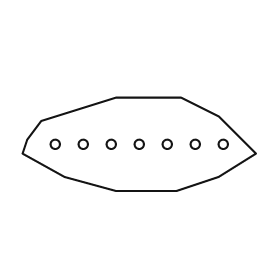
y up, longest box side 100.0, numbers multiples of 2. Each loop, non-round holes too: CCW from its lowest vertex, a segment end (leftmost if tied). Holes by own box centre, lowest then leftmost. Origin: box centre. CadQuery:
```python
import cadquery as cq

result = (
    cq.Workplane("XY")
    .moveTo(-10.0, -20.0)
    .lineTo(16.0, -20.0)
    .lineTo(34.0, -14.0)
    .lineTo(50.0, -4.0)
    .lineTo(34.0, 12.0)
    .lineTo(18.0, 20.0)
    .lineTo(-10.0, 20.0)
    .lineTo(-42.0, 10.0)
    .lineTo(-48.0, 2.0)
    .lineTo(-50.0, -4.0)
    .lineTo(-32.0, -14.0)
    .close()
    .moveTo(-36.0, 0.0)
    .circle(2.0)
    .moveTo(-24.0, 0.0)
    .circle(2.0)
    .moveTo(-12.0, 0.0)
    .circle(2.0)
    .moveTo(0.0, 0.0)
    .circle(2.0)
    .moveTo(12.0, 0.0)
    .circle(2.0)
    .moveTo(24.0, 0.0)
    .circle(2.0)
    .moveTo(36.0, 0.0)
    .circle(2.0)
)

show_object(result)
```